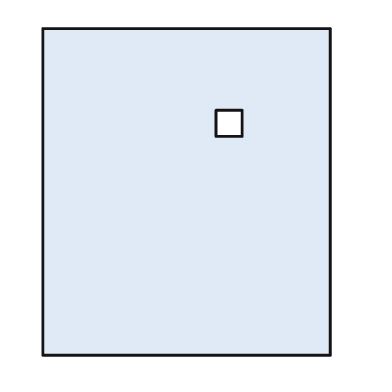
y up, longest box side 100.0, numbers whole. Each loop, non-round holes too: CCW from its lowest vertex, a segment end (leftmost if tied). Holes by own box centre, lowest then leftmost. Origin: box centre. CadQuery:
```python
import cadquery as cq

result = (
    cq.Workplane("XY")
    .moveTo(-44.0, -50.0)
    .lineTo(44.0, -50.0)
    .lineTo(44.0, 50.0)
    .lineTo(-44.0, 50.0)
    .close()
    .moveTo(9.0, 17.0)
    .lineTo(17.0, 17.0)
    .lineTo(17.0, 25.0)
    .lineTo(9.0, 25.0)
    .close()
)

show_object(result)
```